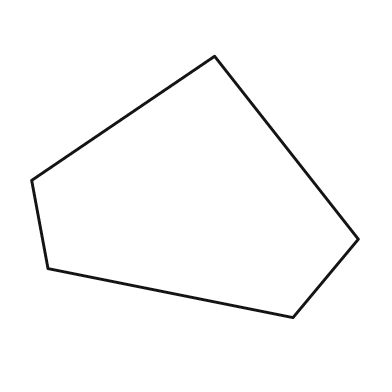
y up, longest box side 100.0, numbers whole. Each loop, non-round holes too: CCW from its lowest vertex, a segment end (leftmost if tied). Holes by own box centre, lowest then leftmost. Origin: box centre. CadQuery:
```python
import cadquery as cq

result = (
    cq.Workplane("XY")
    .moveTo(30.0, -40.0)
    .lineTo(50.0, -16.0)
    .lineTo(6.0, 40.0)
    .lineTo(-50.0, 2.0)
    .lineTo(-45.0, -25.0)
    .close()
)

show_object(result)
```